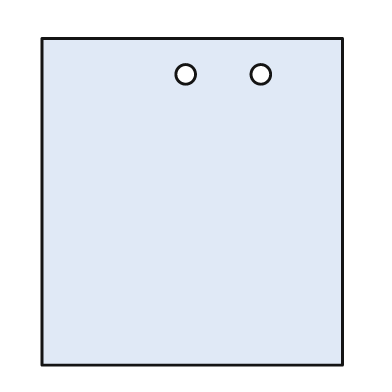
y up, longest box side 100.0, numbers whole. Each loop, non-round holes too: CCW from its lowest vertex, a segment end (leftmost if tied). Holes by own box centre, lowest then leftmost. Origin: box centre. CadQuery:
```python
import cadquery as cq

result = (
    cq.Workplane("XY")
    .moveTo(-46.0, -50.0)
    .lineTo(46.0, -50.0)
    .lineTo(46.0, 50.0)
    .lineTo(-46.0, 50.0)
    .close()
    .moveTo(-2.0, 39.0)
    .circle(3.0)
    .moveTo(21.0, 39.0)
    .circle(3.0)
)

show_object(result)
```